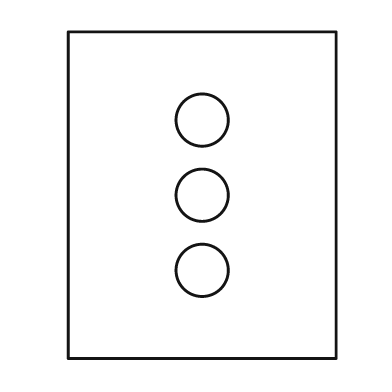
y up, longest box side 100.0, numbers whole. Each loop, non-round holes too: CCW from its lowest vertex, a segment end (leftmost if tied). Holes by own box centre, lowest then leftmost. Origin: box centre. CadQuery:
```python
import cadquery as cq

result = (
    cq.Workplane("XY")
    .moveTo(-41.0, -50.0)
    .lineTo(41.0, -50.0)
    .lineTo(41.0, 50.0)
    .lineTo(-41.0, 50.0)
    .close()
    .moveTo(0.0, -23.0)
    .circle(8.0)
    .moveTo(0.0, 0.0)
    .circle(8.0)
    .moveTo(0.0, 23.0)
    .circle(8.0)
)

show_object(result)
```